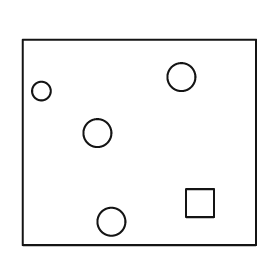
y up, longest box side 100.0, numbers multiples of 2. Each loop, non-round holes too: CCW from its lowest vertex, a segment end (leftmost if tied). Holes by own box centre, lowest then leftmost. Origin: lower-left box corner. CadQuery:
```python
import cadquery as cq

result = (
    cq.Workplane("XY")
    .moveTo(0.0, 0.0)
    .lineTo(100.0, 0.0)
    .lineTo(100.0, 88.0)
    .lineTo(0.0, 88.0)
    .close()
    .moveTo(38.0, 10.0)
    .circle(6.0)
    .moveTo(70.0, 12.0)
    .lineTo(82.0, 12.0)
    .lineTo(82.0, 24.0)
    .lineTo(70.0, 24.0)
    .close()
    .moveTo(32.0, 48.0)
    .circle(6.0)
    .moveTo(8.0, 66.0)
    .circle(4.0)
    .moveTo(68.0, 72.0)
    .circle(6.0)
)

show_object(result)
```